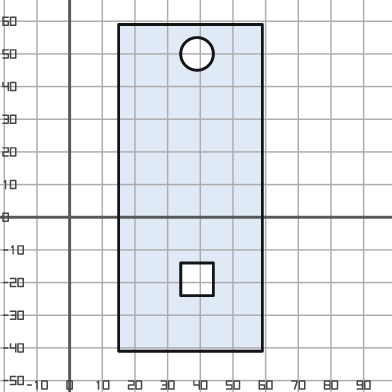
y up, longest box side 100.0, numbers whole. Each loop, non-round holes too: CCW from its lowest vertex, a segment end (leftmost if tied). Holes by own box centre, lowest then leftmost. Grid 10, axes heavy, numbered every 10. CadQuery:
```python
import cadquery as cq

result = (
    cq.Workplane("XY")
    .moveTo(15.0, -41.0)
    .lineTo(59.0, -41.0)
    .lineTo(59.0, 59.0)
    .lineTo(15.0, 59.0)
    .close()
    .moveTo(34.0, -24.0)
    .lineTo(44.0, -24.0)
    .lineTo(44.0, -14.0)
    .lineTo(34.0, -14.0)
    .close()
    .moveTo(39.0, 50.0)
    .circle(5.0)
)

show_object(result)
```